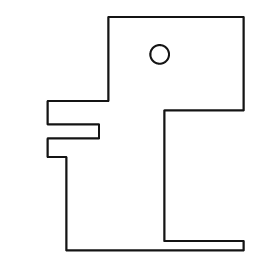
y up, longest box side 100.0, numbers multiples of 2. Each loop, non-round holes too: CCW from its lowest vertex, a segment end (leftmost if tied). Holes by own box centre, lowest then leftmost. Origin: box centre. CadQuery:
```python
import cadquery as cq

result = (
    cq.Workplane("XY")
    .moveTo(-34.0, -50.0)
    .lineTo(42.0, -50.0)
    .lineTo(42.0, -46.0)
    .lineTo(8.0, -46.0)
    .lineTo(8.0, 10.0)
    .lineTo(42.0, 10.0)
    .lineTo(42.0, 50.0)
    .lineTo(-16.0, 50.0)
    .lineTo(-16.0, 14.0)
    .lineTo(-42.0, 14.0)
    .lineTo(-42.0, 4.0)
    .lineTo(-20.0, 4.0)
    .lineTo(-20.0, -2.0)
    .lineTo(-42.0, -2.0)
    .lineTo(-42.0, -10.0)
    .lineTo(-34.0, -10.0)
    .close()
    .moveTo(6.0, 34.0)
    .circle(4.0)
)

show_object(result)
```